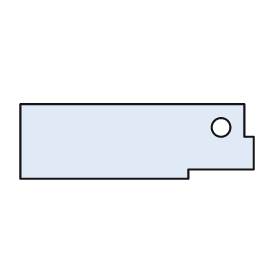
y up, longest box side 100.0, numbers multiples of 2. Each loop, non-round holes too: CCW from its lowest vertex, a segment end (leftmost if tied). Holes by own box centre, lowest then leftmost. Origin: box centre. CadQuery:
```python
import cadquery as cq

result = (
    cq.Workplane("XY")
    .moveTo(-50.0, -16.0)
    .lineTo(22.0, -16.0)
    .lineTo(22.0, -12.0)
    .lineTo(50.0, -12.0)
    .lineTo(50.0, 2.0)
    .lineTo(46.0, 2.0)
    .lineTo(46.0, 16.0)
    .lineTo(-50.0, 16.0)
    .close()
    .moveTo(36.0, 6.0)
    .circle(4.0)
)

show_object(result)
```